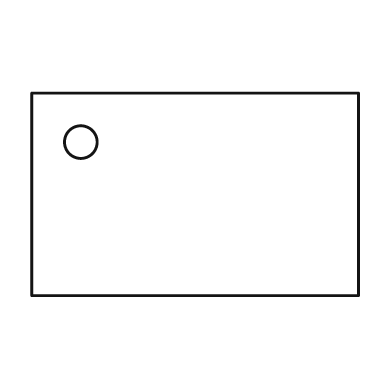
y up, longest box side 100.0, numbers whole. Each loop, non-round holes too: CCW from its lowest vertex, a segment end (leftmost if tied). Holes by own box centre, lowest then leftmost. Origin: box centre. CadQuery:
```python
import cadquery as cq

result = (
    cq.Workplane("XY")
    .moveTo(-50.0, -31.0)
    .lineTo(50.0, -31.0)
    .lineTo(50.0, 31.0)
    .lineTo(-50.0, 31.0)
    .close()
    .moveTo(-35.0, 16.0)
    .circle(5.0)
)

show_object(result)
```